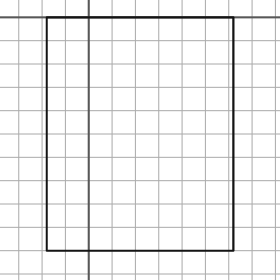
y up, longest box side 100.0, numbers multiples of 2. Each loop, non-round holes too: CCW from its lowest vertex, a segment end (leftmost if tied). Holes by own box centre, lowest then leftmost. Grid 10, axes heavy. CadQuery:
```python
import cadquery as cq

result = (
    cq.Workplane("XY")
    .moveTo(-18.0, -100.0)
    .lineTo(62.0, -100.0)
    .lineTo(62.0, 0.0)
    .lineTo(-18.0, 0.0)
    .close()
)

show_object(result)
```